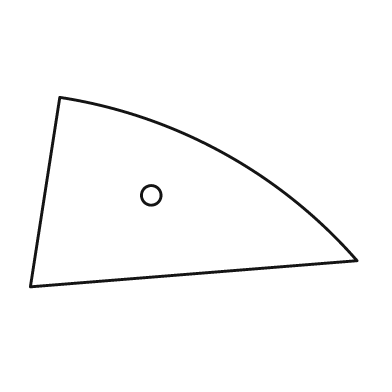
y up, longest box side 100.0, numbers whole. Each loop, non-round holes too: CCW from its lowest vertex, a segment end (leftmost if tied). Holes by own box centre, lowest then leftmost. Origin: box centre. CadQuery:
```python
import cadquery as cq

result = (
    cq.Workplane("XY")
    .moveTo(-50.0, -29.0)
    .lineTo(50.0, -21.0)
    .threePointArc((9.0, 12.0), (-41.0, 29.0))
    .close()
    .moveTo(-13.0, -1.0)
    .circle(3.0)
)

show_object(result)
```